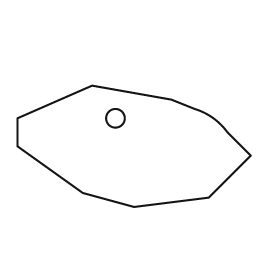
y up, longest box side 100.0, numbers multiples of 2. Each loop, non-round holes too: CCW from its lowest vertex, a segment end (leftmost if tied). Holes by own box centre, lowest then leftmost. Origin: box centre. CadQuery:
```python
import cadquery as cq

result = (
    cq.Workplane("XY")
    .moveTo(0.0, -26.0)
    .lineTo(32.0, -22.0)
    .lineTo(50.0, -4.0)
    .lineTo(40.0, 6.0)
    .threePointArc((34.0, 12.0), (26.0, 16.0))
    .lineTo(16.0, 20.0)
    .lineTo(-18.0, 26.0)
    .lineTo(-50.0, 12.0)
    .lineTo(-50.0, 0.0)
    .lineTo(-22.0, -20.0)
    .close()
    .moveTo(-8.0, 12.0)
    .circle(4.0)
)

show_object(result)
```